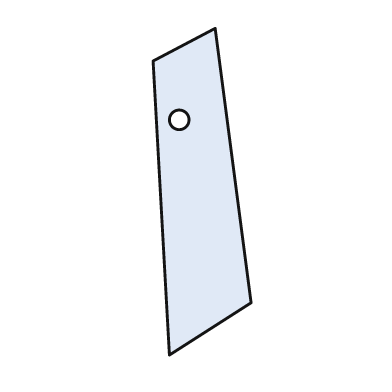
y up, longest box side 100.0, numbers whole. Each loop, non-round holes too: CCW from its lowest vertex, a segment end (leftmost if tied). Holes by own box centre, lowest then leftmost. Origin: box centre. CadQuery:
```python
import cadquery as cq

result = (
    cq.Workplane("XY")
    .moveTo(-10.0, -50.0)
    .lineTo(15.0, -34.0)
    .lineTo(4.0, 50.0)
    .lineTo(-15.0, 40.0)
    .close()
    .moveTo(-7.0, 22.0)
    .circle(3.0)
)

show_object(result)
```